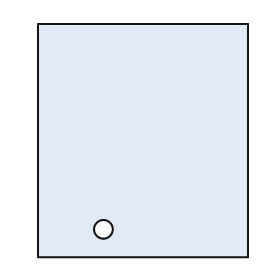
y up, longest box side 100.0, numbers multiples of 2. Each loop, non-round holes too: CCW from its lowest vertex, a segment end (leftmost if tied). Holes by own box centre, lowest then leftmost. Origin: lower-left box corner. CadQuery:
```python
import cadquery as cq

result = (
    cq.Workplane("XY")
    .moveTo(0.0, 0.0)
    .lineTo(90.0, 0.0)
    .lineTo(90.0, 100.0)
    .lineTo(0.0, 100.0)
    .close()
    .moveTo(28.0, 12.0)
    .circle(4.0)
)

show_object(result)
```